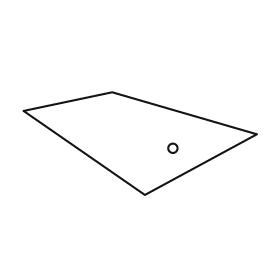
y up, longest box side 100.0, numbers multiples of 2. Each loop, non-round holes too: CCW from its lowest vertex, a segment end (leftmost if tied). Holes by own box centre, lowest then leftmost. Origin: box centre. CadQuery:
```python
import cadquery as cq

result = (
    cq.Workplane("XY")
    .moveTo(2.0, -22.0)
    .lineTo(50.0, 4.0)
    .lineTo(-12.0, 22.0)
    .lineTo(-50.0, 14.0)
    .close()
    .moveTo(14.0, -2.0)
    .circle(2.0)
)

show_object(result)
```